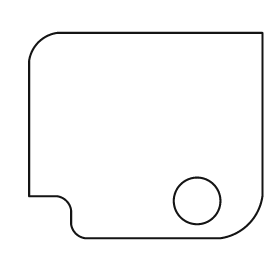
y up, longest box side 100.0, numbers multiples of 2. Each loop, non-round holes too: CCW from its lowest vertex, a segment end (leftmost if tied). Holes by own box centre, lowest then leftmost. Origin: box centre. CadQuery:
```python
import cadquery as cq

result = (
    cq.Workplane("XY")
    .moveTo(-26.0, -44.0)
    .lineTo(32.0, -44.0)
    .threePointArc((44.0, -38.0), (50.0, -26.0))
    .lineTo(50.0, 44.0)
    .lineTo(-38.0, 44.0)
    .threePointArc((-46.0, 40.0), (-50.0, 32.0))
    .lineTo(-50.0, -26.0)
    .lineTo(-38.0, -26.0)
    .threePointArc((-34.0, -28.0), (-32.0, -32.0))
    .lineTo(-32.0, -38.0)
    .threePointArc((-30.0, -42.0), (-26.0, -44.0))
    .close()
    .moveTo(22.0, -28.0)
    .circle(10.0)
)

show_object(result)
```